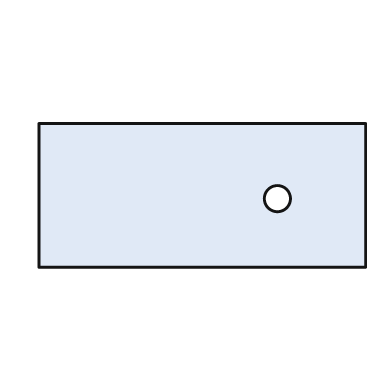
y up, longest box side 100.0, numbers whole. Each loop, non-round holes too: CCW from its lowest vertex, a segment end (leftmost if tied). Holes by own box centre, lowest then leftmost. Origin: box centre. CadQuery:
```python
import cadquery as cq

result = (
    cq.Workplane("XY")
    .moveTo(-50.0, -22.0)
    .lineTo(50.0, -22.0)
    .lineTo(50.0, 22.0)
    .lineTo(-50.0, 22.0)
    .close()
    .moveTo(23.0, -1.0)
    .circle(4.0)
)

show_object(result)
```